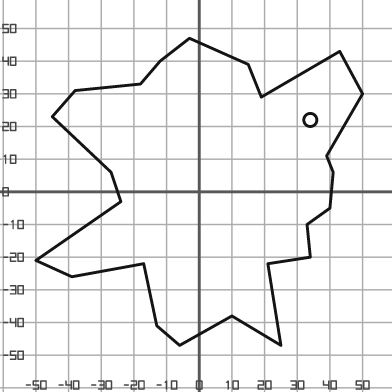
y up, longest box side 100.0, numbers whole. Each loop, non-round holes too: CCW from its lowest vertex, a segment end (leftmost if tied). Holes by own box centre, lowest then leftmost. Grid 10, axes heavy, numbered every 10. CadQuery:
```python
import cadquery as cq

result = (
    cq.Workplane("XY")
    .moveTo(-6.0, -47.0)
    .lineTo(10.0, -38.0)
    .lineTo(25.0, -47.0)
    .lineTo(21.0, -22.0)
    .lineTo(34.0, -20.0)
    .lineTo(33.0, -10.0)
    .lineTo(40.0, -5.0)
    .lineTo(41.0, 6.0)
    .lineTo(39.0, 11.0)
    .lineTo(50.0, 30.0)
    .lineTo(43.0, 43.0)
    .lineTo(19.0, 29.0)
    .lineTo(15.0, 39.0)
    .lineTo(-3.0, 47.0)
    .lineTo(-12.0, 40.0)
    .lineTo(-18.0, 33.0)
    .lineTo(-38.0, 31.0)
    .lineTo(-45.0, 23.0)
    .lineTo(-27.0, 6.0)
    .lineTo(-24.0, -3.0)
    .lineTo(-50.0, -21.0)
    .lineTo(-39.0, -26.0)
    .lineTo(-17.0, -22.0)
    .lineTo(-13.0, -41.0)
    .close()
    .moveTo(34.0, 22.0)
    .circle(2.0)
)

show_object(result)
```